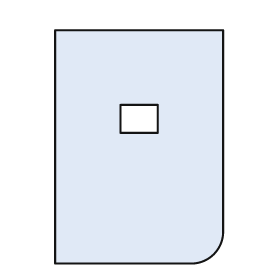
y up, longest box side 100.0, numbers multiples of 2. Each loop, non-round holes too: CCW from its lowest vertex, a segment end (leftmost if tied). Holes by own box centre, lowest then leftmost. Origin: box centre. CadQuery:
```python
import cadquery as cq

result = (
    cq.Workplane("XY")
    .moveTo(-36.0, -50.0)
    .lineTo(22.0, -50.0)
    .threePointArc((32.0, -46.0), (36.0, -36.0))
    .lineTo(36.0, 50.0)
    .lineTo(-36.0, 50.0)
    .close()
    .moveTo(-8.0, 6.0)
    .lineTo(8.0, 6.0)
    .lineTo(8.0, 18.0)
    .lineTo(-8.0, 18.0)
    .close()
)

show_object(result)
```